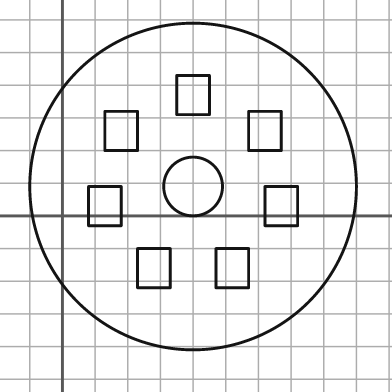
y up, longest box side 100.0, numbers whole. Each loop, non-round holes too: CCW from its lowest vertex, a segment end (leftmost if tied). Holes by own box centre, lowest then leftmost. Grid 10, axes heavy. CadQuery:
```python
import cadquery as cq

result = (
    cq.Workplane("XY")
    .moveTo(40.0, 9.0)
    .circle(50.0)
    .moveTo(23.0, -22.0)
    .lineTo(33.0, -22.0)
    .lineTo(33.0, -10.0)
    .lineTo(23.0, -10.0)
    .close()
    .moveTo(47.0, -22.0)
    .lineTo(57.0, -22.0)
    .lineTo(57.0, -10.0)
    .lineTo(47.0, -10.0)
    .close()
    .moveTo(8.0, -3.0)
    .lineTo(18.0, -3.0)
    .lineTo(18.0, 9.0)
    .lineTo(8.0, 9.0)
    .close()
    .moveTo(62.0, -3.0)
    .lineTo(72.0, -3.0)
    .lineTo(72.0, 9.0)
    .lineTo(62.0, 9.0)
    .close()
    .moveTo(40.0, 9.0)
    .circle(9.0)
    .moveTo(13.0, 20.0)
    .lineTo(23.0, 20.0)
    .lineTo(23.0, 32.0)
    .lineTo(13.0, 32.0)
    .close()
    .moveTo(57.0, 20.0)
    .lineTo(67.0, 20.0)
    .lineTo(67.0, 32.0)
    .lineTo(57.0, 32.0)
    .close()
    .moveTo(35.0, 31.0)
    .lineTo(45.0, 31.0)
    .lineTo(45.0, 43.0)
    .lineTo(35.0, 43.0)
    .close()
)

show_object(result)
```